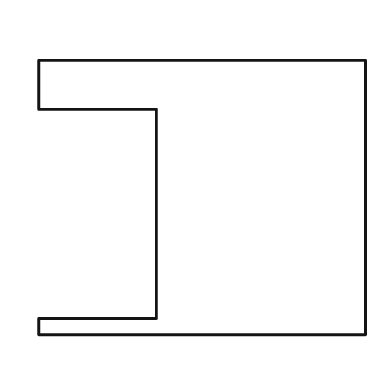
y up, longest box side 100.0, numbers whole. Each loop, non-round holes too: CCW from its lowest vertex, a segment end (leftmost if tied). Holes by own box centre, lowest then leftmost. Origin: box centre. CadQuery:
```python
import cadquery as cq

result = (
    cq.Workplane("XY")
    .moveTo(-50.0, -42.0)
    .lineTo(50.0, -42.0)
    .lineTo(50.0, 42.0)
    .lineTo(-50.0, 42.0)
    .lineTo(-50.0, 27.0)
    .lineTo(-14.0, 27.0)
    .lineTo(-14.0, -37.0)
    .lineTo(-50.0, -37.0)
    .close()
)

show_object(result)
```